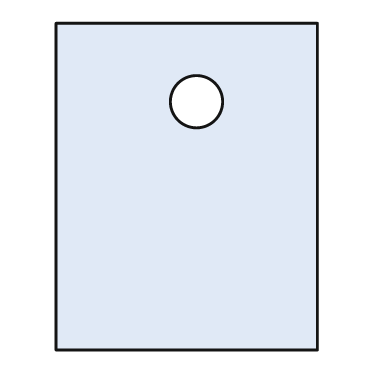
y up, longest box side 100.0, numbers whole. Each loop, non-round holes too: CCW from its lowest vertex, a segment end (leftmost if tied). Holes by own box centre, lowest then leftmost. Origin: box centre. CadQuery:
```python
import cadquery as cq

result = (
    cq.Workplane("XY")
    .moveTo(-40.0, -50.0)
    .lineTo(40.0, -50.0)
    .lineTo(40.0, 50.0)
    .lineTo(-40.0, 50.0)
    .close()
    .moveTo(3.0, 26.0)
    .circle(8.0)
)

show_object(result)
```